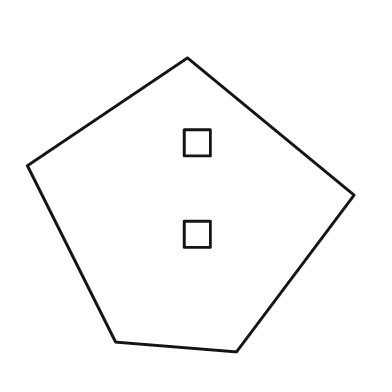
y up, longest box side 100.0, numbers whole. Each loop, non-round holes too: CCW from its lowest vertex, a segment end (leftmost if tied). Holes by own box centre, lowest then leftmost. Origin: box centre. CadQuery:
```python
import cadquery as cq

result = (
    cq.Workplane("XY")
    .moveTo(14.0, -45.0)
    .lineTo(50.0, 3.0)
    .lineTo(-1.0, 45.0)
    .lineTo(-50.0, 12.0)
    .lineTo(-23.0, -42.0)
    .close()
    .moveTo(-2.0, -13.0)
    .lineTo(6.0, -13.0)
    .lineTo(6.0, -5.0)
    .lineTo(-2.0, -5.0)
    .close()
    .moveTo(-2.0, 15.0)
    .lineTo(6.0, 15.0)
    .lineTo(6.0, 23.0)
    .lineTo(-2.0, 23.0)
    .close()
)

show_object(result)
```